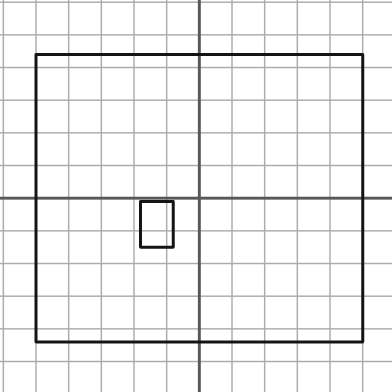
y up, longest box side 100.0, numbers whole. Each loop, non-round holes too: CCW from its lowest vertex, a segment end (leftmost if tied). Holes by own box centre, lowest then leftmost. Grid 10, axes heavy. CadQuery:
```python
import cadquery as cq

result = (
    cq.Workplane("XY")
    .moveTo(-50.0, -44.0)
    .lineTo(50.0, -44.0)
    .lineTo(50.0, 44.0)
    .lineTo(-50.0, 44.0)
    .close()
    .moveTo(-18.0, -15.0)
    .lineTo(-8.0, -15.0)
    .lineTo(-8.0, -1.0)
    .lineTo(-18.0, -1.0)
    .close()
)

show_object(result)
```